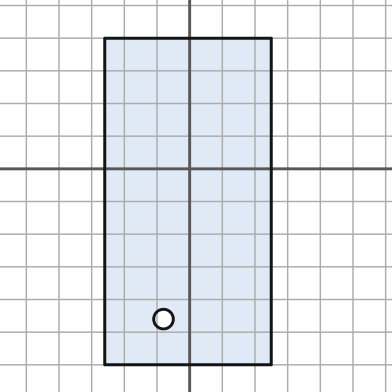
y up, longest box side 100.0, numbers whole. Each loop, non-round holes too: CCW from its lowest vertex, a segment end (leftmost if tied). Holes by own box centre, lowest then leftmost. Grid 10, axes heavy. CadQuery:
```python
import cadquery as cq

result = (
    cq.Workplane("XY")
    .moveTo(-26.0, -60.0)
    .lineTo(25.0, -60.0)
    .lineTo(25.0, 40.0)
    .lineTo(-26.0, 40.0)
    .close()
    .moveTo(-8.0, -46.0)
    .circle(3.0)
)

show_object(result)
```